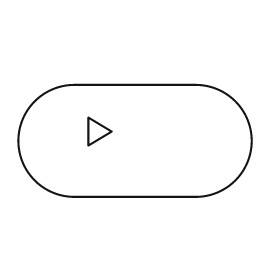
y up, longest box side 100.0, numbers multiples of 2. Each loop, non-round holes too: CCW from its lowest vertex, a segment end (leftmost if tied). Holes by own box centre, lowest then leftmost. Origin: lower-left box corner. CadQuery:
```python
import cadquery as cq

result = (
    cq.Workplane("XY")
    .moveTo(24.0, 0.0)
    .lineTo(76.0, 0.0)
    .threePointArc((100.0, 24.0), (76.0, 48.0))
    .lineTo(24.0, 48.0)
    .threePointArc((0.0, 24.0), (24.0, 0.0))
    .close()
    .moveTo(30.0, 22.0)
    .lineTo(40.0, 28.0)
    .lineTo(30.0, 34.0)
    .close()
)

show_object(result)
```